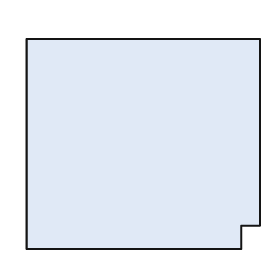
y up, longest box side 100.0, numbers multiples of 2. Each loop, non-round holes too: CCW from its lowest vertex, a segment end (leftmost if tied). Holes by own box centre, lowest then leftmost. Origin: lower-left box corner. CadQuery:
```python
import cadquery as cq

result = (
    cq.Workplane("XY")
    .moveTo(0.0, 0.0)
    .lineTo(92.0, 0.0)
    .lineTo(92.0, 10.0)
    .lineTo(100.0, 10.0)
    .lineTo(100.0, 90.0)
    .lineTo(0.0, 90.0)
    .close()
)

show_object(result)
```